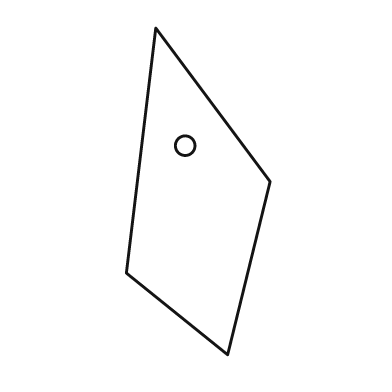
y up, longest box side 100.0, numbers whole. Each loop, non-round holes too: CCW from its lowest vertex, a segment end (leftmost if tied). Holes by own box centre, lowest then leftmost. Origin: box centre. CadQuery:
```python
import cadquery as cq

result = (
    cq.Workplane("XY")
    .moveTo(9.0, -50.0)
    .lineTo(22.0, 3.0)
    .lineTo(-13.0, 50.0)
    .lineTo(-22.0, -25.0)
    .close()
    .moveTo(-4.0, 14.0)
    .circle(3.0)
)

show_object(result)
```